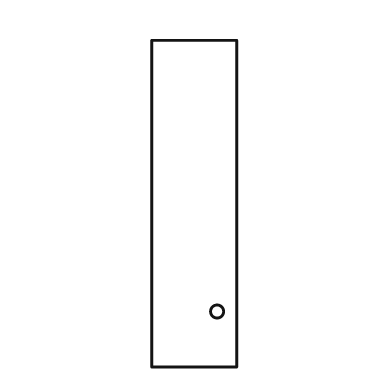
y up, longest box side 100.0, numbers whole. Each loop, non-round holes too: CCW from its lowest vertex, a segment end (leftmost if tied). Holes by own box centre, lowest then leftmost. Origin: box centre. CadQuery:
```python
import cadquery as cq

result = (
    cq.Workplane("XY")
    .moveTo(-13.0, -50.0)
    .lineTo(13.0, -50.0)
    .lineTo(13.0, 50.0)
    .lineTo(-13.0, 50.0)
    .close()
    .moveTo(7.0, -33.0)
    .circle(2.0)
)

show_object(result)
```